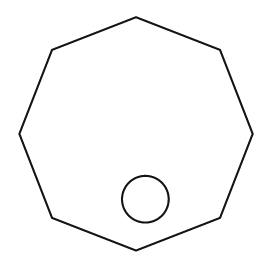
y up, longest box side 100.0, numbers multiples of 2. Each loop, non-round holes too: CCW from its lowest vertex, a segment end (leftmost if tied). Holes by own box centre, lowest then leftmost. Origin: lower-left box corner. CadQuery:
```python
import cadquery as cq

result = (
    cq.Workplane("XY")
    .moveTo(50.0, 0.0)
    .lineTo(86.0, 14.0)
    .lineTo(100.0, 50.0)
    .lineTo(86.0, 86.0)
    .lineTo(50.0, 100.0)
    .lineTo(14.0, 86.0)
    .lineTo(0.0, 50.0)
    .lineTo(14.0, 14.0)
    .close()
    .moveTo(54.0, 22.0)
    .circle(10.0)
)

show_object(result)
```